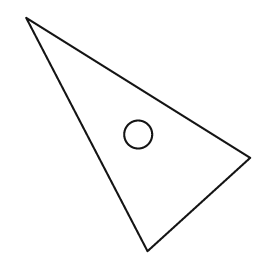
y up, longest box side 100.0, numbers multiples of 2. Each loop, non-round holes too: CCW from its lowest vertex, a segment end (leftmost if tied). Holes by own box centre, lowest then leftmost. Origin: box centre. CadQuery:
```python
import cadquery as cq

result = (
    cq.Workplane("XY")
    .moveTo(4.0, -50.0)
    .lineTo(48.0, -10.0)
    .lineTo(-48.0, 50.0)
    .close()
    .moveTo(0.0, 0.0)
    .circle(6.0)
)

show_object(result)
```